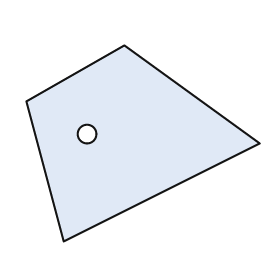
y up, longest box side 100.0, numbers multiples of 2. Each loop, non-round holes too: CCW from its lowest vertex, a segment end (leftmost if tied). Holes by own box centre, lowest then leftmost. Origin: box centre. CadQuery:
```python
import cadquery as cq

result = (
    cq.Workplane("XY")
    .moveTo(-34.0, -42.0)
    .lineTo(50.0, 0.0)
    .lineTo(-8.0, 42.0)
    .lineTo(-50.0, 18.0)
    .close()
    .moveTo(-24.0, 4.0)
    .circle(4.0)
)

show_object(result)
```